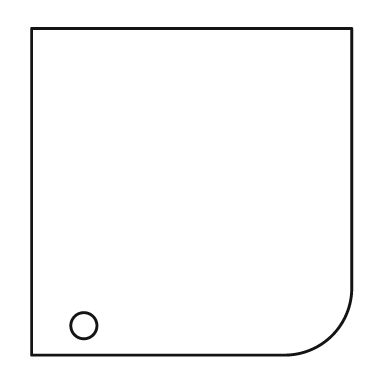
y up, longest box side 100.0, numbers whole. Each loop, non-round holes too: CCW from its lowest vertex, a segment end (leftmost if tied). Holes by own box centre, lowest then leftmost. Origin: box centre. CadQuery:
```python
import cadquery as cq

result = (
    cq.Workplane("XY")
    .moveTo(-49.0, -50.0)
    .lineTo(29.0, -50.0)
    .threePointArc((43.0, -44.0), (49.0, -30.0))
    .lineTo(49.0, 50.0)
    .lineTo(-49.0, 50.0)
    .close()
    .moveTo(-33.0, -41.0)
    .circle(4.0)
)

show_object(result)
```